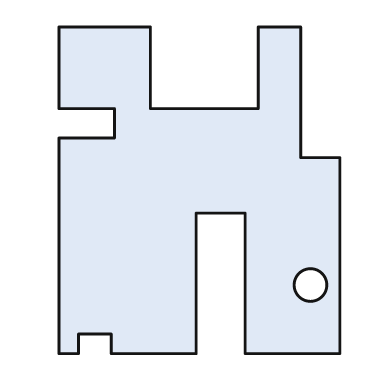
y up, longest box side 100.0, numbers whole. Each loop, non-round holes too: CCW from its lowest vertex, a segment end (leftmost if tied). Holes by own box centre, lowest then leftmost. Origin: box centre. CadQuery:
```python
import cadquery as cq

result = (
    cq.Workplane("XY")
    .moveTo(-43.0, -50.0)
    .lineTo(-37.0, -50.0)
    .lineTo(-37.0, -44.0)
    .lineTo(-27.0, -44.0)
    .lineTo(-27.0, -50.0)
    .lineTo(-1.0, -50.0)
    .lineTo(-1.0, -7.0)
    .lineTo(14.0, -7.0)
    .lineTo(14.0, -50.0)
    .lineTo(43.0, -50.0)
    .lineTo(43.0, 10.0)
    .lineTo(31.0, 10.0)
    .lineTo(31.0, 50.0)
    .lineTo(18.0, 50.0)
    .lineTo(18.0, 25.0)
    .lineTo(-15.0, 25.0)
    .lineTo(-15.0, 50.0)
    .lineTo(-43.0, 50.0)
    .lineTo(-43.0, 25.0)
    .lineTo(-26.0, 25.0)
    .lineTo(-26.0, 16.0)
    .lineTo(-43.0, 16.0)
    .close()
    .moveTo(34.0, -29.0)
    .circle(5.0)
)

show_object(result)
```